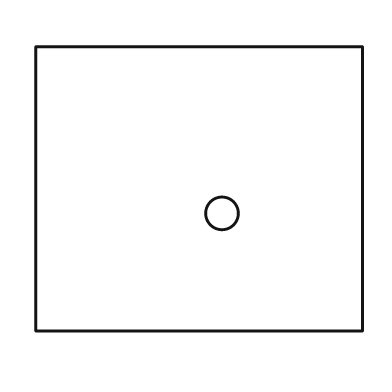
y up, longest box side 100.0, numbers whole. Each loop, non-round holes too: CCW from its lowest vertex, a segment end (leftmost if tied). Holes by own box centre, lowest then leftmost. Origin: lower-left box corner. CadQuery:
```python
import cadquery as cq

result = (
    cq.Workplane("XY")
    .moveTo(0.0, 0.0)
    .lineTo(100.0, 0.0)
    .lineTo(100.0, 87.0)
    .lineTo(0.0, 87.0)
    .close()
    .moveTo(57.0, 36.0)
    .circle(5.0)
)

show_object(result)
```